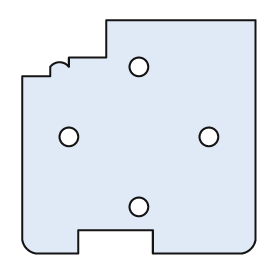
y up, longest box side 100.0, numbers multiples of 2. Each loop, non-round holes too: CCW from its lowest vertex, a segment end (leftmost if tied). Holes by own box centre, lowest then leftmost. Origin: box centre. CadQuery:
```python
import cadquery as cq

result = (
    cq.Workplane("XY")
    .moveTo(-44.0, -50.0)
    .lineTo(-26.0, -50.0)
    .lineTo(-26.0, -40.0)
    .lineTo(6.0, -40.0)
    .lineTo(6.0, -50.0)
    .lineTo(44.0, -50.0)
    .threePointArc((48.0, -48.0), (50.0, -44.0))
    .lineTo(50.0, 50.0)
    .lineTo(-14.0, 50.0)
    .lineTo(-14.0, 34.0)
    .lineTo(-30.0, 34.0)
    .lineTo(-30.0, 30.0)
    .threePointArc((-34.0, 32.0), (-38.0, 30.0))
    .lineTo(-38.0, 26.0)
    .lineTo(-50.0, 26.0)
    .lineTo(-50.0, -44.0)
    .threePointArc((-48.0, -48.0), (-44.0, -50.0))
    .close()
    .moveTo(0.0, -30.0)
    .circle(4.0)
    .moveTo(-30.0, 0.0)
    .circle(4.0)
    .moveTo(30.0, 0.0)
    .circle(4.0)
    .moveTo(0.0, 30.0)
    .circle(4.0)
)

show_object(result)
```